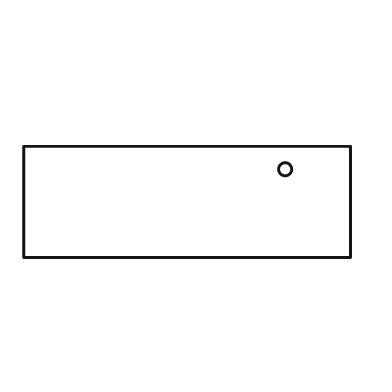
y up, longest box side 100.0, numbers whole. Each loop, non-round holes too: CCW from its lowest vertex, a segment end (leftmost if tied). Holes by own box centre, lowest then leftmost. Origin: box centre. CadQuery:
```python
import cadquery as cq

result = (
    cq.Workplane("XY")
    .moveTo(-50.0, -17.0)
    .lineTo(50.0, -17.0)
    .lineTo(50.0, 17.0)
    .lineTo(-50.0, 17.0)
    .close()
    .moveTo(30.0, 10.0)
    .circle(2.0)
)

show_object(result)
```